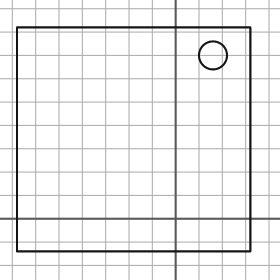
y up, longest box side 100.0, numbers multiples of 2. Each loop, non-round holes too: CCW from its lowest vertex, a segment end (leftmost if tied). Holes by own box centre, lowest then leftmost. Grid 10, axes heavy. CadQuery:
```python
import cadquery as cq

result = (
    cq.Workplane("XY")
    .moveTo(-68.0, -14.0)
    .lineTo(32.0, -14.0)
    .lineTo(32.0, 82.0)
    .lineTo(-68.0, 82.0)
    .close()
    .moveTo(16.0, 70.0)
    .circle(6.0)
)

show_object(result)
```